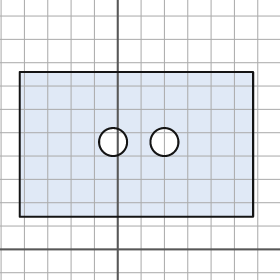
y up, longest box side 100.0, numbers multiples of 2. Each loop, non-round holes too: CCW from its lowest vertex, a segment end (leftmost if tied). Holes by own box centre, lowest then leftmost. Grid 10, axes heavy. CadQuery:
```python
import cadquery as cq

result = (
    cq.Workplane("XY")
    .moveTo(-42.0, 14.0)
    .lineTo(58.0, 14.0)
    .lineTo(58.0, 76.0)
    .lineTo(-42.0, 76.0)
    .close()
    .moveTo(-2.0, 46.0)
    .circle(6.0)
    .moveTo(20.0, 46.0)
    .circle(6.0)
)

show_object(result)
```